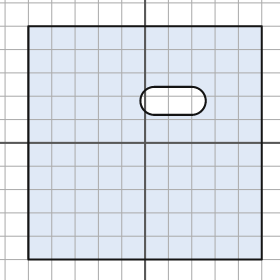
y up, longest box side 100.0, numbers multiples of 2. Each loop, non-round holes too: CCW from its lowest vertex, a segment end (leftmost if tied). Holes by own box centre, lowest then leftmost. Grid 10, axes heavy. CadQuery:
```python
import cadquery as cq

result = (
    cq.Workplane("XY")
    .moveTo(-50.0, -50.0)
    .lineTo(50.0, -50.0)
    .lineTo(50.0, 50.0)
    .lineTo(-50.0, 50.0)
    .close()
    .moveTo(4.0, 12.0)
    .lineTo(20.0, 12.0)
    .threePointArc((26.0, 18.0), (20.0, 24.0))
    .lineTo(4.0, 24.0)
    .threePointArc((-2.0, 18.0), (4.0, 12.0))
    .close()
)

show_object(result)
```